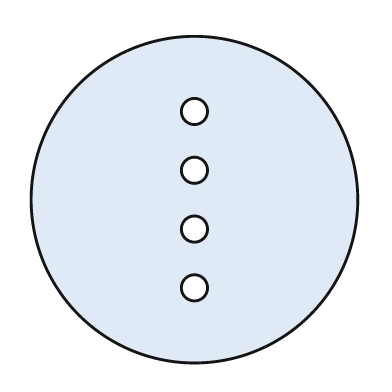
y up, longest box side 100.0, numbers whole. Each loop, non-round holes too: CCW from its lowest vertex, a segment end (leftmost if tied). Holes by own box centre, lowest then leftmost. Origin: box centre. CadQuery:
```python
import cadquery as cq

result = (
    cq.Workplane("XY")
    .moveTo(0.0, 0.0)
    .circle(50.0)
    .moveTo(0.0, -27.0)
    .circle(4.0)
    .moveTo(0.0, -9.0)
    .circle(4.0)
    .moveTo(0.0, 9.0)
    .circle(4.0)
    .moveTo(0.0, 27.0)
    .circle(4.0)
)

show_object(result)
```